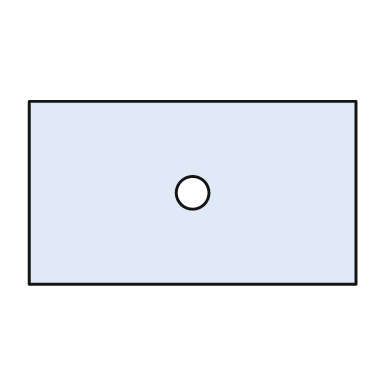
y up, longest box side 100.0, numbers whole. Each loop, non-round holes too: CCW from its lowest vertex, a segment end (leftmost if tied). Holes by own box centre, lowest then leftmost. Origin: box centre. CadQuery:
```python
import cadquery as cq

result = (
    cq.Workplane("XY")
    .moveTo(-50.0, -28.0)
    .lineTo(50.0, -28.0)
    .lineTo(50.0, 28.0)
    .lineTo(-50.0, 28.0)
    .close()
    .moveTo(0.0, 0.0)
    .circle(5.0)
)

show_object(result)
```